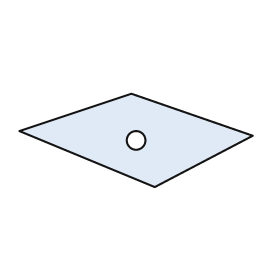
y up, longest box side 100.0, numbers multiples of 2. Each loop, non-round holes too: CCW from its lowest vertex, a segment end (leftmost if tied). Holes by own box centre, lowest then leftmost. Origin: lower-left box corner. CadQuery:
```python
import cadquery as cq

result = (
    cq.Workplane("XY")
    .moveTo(58.0, 0.0)
    .lineTo(100.0, 22.0)
    .lineTo(48.0, 40.0)
    .lineTo(0.0, 24.0)
    .close()
    .moveTo(50.0, 20.0)
    .circle(4.0)
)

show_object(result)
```